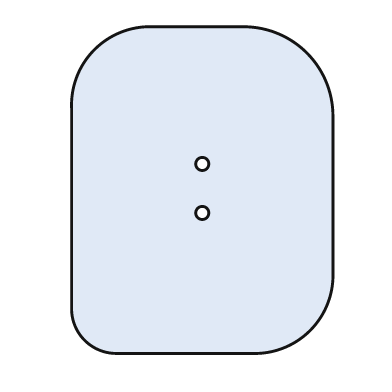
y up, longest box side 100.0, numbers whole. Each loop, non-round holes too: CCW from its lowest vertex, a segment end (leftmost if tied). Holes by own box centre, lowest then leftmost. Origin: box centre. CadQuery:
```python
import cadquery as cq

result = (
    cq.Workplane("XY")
    .moveTo(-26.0, -50.0)
    .lineTo(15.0, -50.0)
    .threePointArc((33.0, -43.0), (40.0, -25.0))
    .lineTo(40.0, 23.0)
    .threePointArc((32.0, 42.0), (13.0, 50.0))
    .lineTo(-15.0, 50.0)
    .threePointArc((-33.0, 43.0), (-40.0, 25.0))
    .lineTo(-40.0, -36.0)
    .threePointArc((-36.0, -46.0), (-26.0, -50.0))
    .close()
    .moveTo(0.0, -7.0)
    .circle(2.0)
    .moveTo(0.0, 8.0)
    .circle(2.0)
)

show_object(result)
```